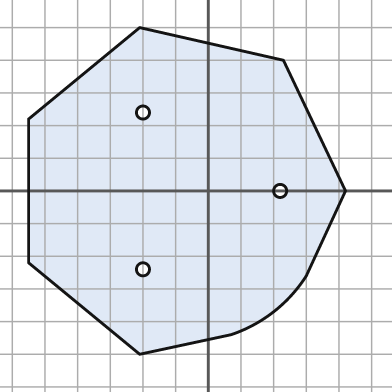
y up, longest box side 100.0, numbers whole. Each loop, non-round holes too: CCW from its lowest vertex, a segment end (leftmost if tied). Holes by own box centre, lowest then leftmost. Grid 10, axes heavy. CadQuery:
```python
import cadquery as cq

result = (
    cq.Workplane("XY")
    .moveTo(-21.0, -50.0)
    .lineTo(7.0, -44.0)
    .threePointArc((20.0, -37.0), (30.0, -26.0))
    .lineTo(42.0, 0.0)
    .lineTo(23.0, 40.0)
    .lineTo(-21.0, 50.0)
    .lineTo(-55.0, 22.0)
    .lineTo(-55.0, -22.0)
    .close()
    .moveTo(-20.0, -24.0)
    .circle(2.0)
    .moveTo(22.0, 0.0)
    .circle(2.0)
    .moveTo(-20.0, 24.0)
    .circle(2.0)
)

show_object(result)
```